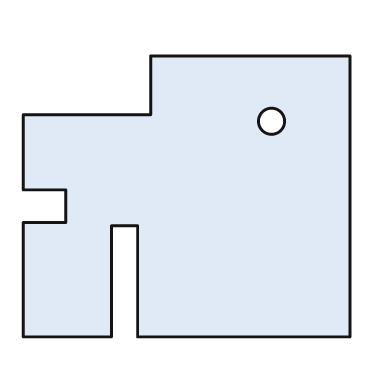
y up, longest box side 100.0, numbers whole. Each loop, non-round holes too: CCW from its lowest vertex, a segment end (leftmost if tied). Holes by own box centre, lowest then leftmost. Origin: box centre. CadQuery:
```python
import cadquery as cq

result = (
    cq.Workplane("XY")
    .moveTo(-50.0, -43.0)
    .lineTo(-23.0, -43.0)
    .lineTo(-23.0, -9.0)
    .lineTo(-15.0, -9.0)
    .lineTo(-15.0, -43.0)
    .lineTo(50.0, -43.0)
    .lineTo(50.0, 43.0)
    .lineTo(-11.0, 43.0)
    .lineTo(-11.0, 25.0)
    .lineTo(-50.0, 25.0)
    .lineTo(-50.0, 2.0)
    .lineTo(-37.0, 2.0)
    .lineTo(-37.0, -8.0)
    .lineTo(-50.0, -8.0)
    .close()
    .moveTo(26.0, 23.0)
    .circle(4.0)
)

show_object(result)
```